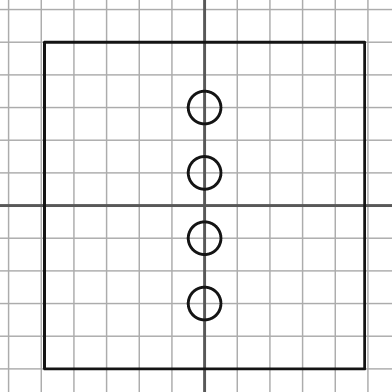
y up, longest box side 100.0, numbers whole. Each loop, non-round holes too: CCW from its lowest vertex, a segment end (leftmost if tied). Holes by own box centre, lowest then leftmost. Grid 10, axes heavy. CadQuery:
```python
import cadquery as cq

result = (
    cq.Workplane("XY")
    .moveTo(-49.0, -50.0)
    .lineTo(49.0, -50.0)
    .lineTo(49.0, 50.0)
    .lineTo(-49.0, 50.0)
    .close()
    .moveTo(0.0, -30.0)
    .circle(5.0)
    .moveTo(0.0, -10.0)
    .circle(5.0)
    .moveTo(0.0, 10.0)
    .circle(5.0)
    .moveTo(0.0, 30.0)
    .circle(5.0)
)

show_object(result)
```